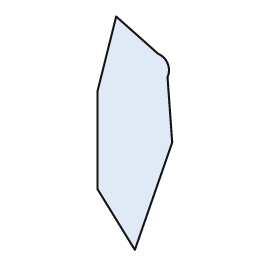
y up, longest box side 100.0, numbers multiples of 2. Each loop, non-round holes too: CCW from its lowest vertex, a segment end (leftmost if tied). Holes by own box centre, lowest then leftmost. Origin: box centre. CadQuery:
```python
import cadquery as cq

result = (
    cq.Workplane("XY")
    .moveTo(0.0, -50.0)
    .lineTo(16.0, -4.0)
    .lineTo(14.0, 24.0)
    .threePointArc((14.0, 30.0), (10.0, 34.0))
    .lineTo(-8.0, 50.0)
    .lineTo(-16.0, 18.0)
    .lineTo(-16.0, -24.0)
    .close()
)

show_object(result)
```